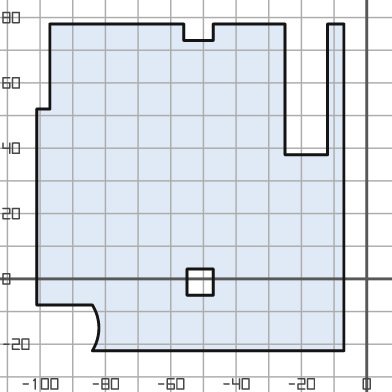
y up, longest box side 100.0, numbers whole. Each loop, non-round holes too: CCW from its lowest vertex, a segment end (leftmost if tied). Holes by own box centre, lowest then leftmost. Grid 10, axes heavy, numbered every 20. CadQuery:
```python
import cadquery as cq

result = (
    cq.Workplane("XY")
    .moveTo(-84.0, -22.0)
    .lineTo(-7.0, -22.0)
    .lineTo(-7.0, 78.0)
    .lineTo(-12.0, 78.0)
    .lineTo(-12.0, 38.0)
    .lineTo(-25.0, 38.0)
    .lineTo(-25.0, 78.0)
    .lineTo(-47.0, 78.0)
    .lineTo(-47.0, 73.0)
    .lineTo(-56.0, 73.0)
    .lineTo(-56.0, 78.0)
    .lineTo(-97.0, 78.0)
    .lineTo(-97.0, 52.0)
    .lineTo(-101.0, 52.0)
    .lineTo(-101.0, -8.0)
    .lineTo(-84.0, -8.0)
    .threePointArc((-82.0, -15.0), (-84.0, -22.0))
    .close()
    .moveTo(-55.0, -5.0)
    .lineTo(-47.0, -5.0)
    .lineTo(-47.0, 3.0)
    .lineTo(-55.0, 3.0)
    .close()
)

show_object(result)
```